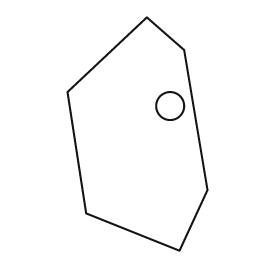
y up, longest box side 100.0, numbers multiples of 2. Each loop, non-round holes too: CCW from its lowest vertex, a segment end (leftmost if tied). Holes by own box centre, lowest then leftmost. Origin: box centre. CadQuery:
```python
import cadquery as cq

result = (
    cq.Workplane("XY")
    .moveTo(18.0, -50.0)
    .lineTo(30.0, -24.0)
    .lineTo(20.0, 36.0)
    .lineTo(4.0, 50.0)
    .lineTo(-30.0, 18.0)
    .lineTo(-22.0, -34.0)
    .close()
    .moveTo(14.0, 12.0)
    .circle(6.0)
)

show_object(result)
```